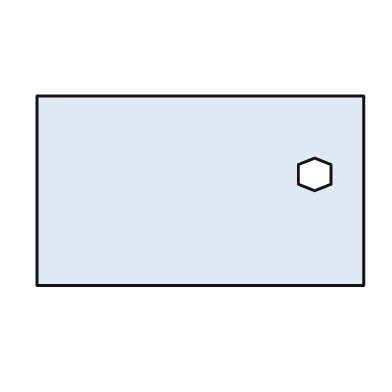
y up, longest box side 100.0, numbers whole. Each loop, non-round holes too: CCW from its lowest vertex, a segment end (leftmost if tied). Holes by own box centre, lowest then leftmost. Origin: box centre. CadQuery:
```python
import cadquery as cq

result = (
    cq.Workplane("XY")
    .moveTo(-50.0, -29.0)
    .lineTo(50.0, -29.0)
    .lineTo(50.0, 29.0)
    .lineTo(-50.0, 29.0)
    .close()
    .moveTo(35.0, 0.0)
    .lineTo(40.0, 2.0)
    .lineTo(40.0, 8.0)
    .lineTo(35.0, 10.0)
    .lineTo(30.0, 8.0)
    .lineTo(30.0, 2.0)
    .close()
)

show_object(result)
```